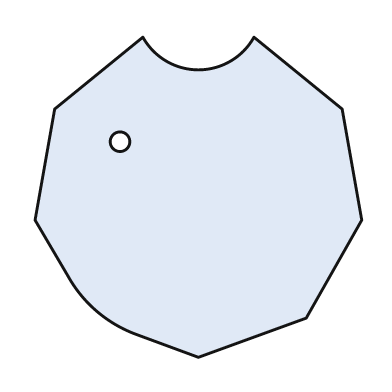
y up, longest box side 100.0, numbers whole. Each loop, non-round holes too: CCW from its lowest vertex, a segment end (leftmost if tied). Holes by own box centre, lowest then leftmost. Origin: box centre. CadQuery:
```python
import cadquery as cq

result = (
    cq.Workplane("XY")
    .moveTo(0.0, -49.0)
    .lineTo(33.0, -37.0)
    .lineTo(50.0, -7.0)
    .lineTo(44.0, 27.0)
    .lineTo(17.0, 49.0)
    .threePointArc((0.0, 39.0), (-17.0, 49.0))
    .lineTo(-44.0, 27.0)
    .lineTo(-50.0, -7.0)
    .lineTo(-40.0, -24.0)
    .threePointArc((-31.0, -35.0), (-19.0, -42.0))
    .close()
    .moveTo(-24.0, 17.0)
    .circle(3.0)
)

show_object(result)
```